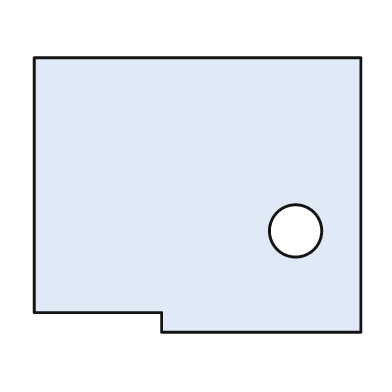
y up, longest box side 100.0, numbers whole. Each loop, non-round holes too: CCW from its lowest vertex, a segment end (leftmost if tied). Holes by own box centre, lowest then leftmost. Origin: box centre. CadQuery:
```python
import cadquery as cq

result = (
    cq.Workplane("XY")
    .moveTo(-11.0, -42.0)
    .lineTo(50.0, -42.0)
    .lineTo(50.0, 42.0)
    .lineTo(-50.0, 42.0)
    .lineTo(-50.0, -36.0)
    .lineTo(-11.0, -36.0)
    .close()
    .moveTo(30.0, -11.0)
    .circle(8.0)
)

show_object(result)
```